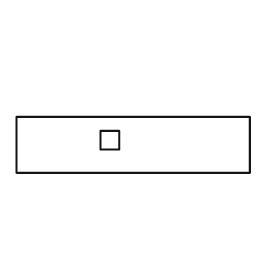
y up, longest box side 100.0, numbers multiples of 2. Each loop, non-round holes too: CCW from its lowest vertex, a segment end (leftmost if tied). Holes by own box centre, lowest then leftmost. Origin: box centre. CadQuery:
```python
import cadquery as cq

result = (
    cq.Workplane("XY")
    .moveTo(-50.0, -12.0)
    .lineTo(50.0, -12.0)
    .lineTo(50.0, 12.0)
    .lineTo(-50.0, 12.0)
    .close()
    .moveTo(-14.0, -2.0)
    .lineTo(-6.0, -2.0)
    .lineTo(-6.0, 6.0)
    .lineTo(-14.0, 6.0)
    .close()
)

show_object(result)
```